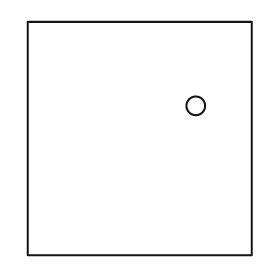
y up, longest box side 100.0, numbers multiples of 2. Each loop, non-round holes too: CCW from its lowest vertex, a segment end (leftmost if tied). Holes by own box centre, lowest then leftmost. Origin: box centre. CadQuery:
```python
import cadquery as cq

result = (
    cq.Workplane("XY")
    .moveTo(-48.0, -50.0)
    .lineTo(48.0, -50.0)
    .lineTo(48.0, 50.0)
    .lineTo(-48.0, 50.0)
    .close()
    .moveTo(24.0, 14.0)
    .circle(4.0)
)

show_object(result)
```